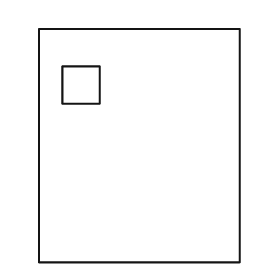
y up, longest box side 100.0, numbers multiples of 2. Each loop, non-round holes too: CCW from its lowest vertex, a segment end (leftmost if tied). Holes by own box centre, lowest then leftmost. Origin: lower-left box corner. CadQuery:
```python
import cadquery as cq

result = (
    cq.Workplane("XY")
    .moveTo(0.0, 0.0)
    .lineTo(86.0, 0.0)
    .lineTo(86.0, 100.0)
    .lineTo(0.0, 100.0)
    .close()
    .moveTo(10.0, 68.0)
    .lineTo(26.0, 68.0)
    .lineTo(26.0, 84.0)
    .lineTo(10.0, 84.0)
    .close()
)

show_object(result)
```